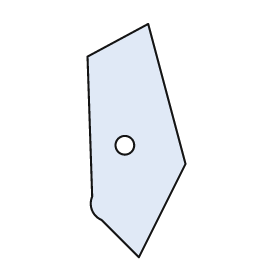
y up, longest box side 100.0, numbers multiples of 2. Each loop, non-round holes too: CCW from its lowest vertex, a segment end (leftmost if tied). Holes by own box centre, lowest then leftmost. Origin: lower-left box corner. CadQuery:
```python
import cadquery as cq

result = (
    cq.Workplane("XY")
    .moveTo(22.0, 0.0)
    .lineTo(42.0, 40.0)
    .lineTo(26.0, 100.0)
    .lineTo(0.0, 86.0)
    .lineTo(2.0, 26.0)
    .threePointArc((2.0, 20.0), (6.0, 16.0))
    .close()
    .moveTo(16.0, 48.0)
    .circle(4.0)
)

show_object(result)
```